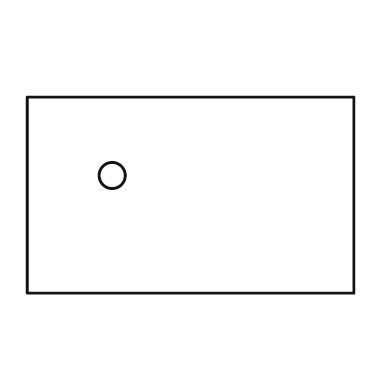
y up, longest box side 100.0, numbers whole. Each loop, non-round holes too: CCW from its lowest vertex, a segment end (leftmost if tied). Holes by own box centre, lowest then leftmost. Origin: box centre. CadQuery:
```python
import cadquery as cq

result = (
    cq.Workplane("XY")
    .moveTo(-50.0, -30.0)
    .lineTo(50.0, -30.0)
    .lineTo(50.0, 30.0)
    .lineTo(-50.0, 30.0)
    .close()
    .moveTo(-24.0, 6.0)
    .circle(4.0)
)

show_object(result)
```